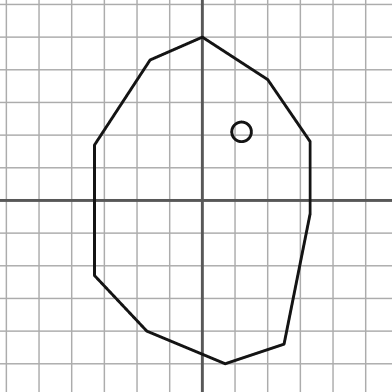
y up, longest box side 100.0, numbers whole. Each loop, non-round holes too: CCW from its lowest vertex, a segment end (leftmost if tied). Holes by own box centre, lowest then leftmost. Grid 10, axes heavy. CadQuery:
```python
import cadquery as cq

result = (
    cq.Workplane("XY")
    .moveTo(7.0, -50.0)
    .lineTo(25.0, -44.0)
    .lineTo(33.0, -4.0)
    .lineTo(33.0, 18.0)
    .lineTo(20.0, 37.0)
    .lineTo(0.0, 50.0)
    .lineTo(-16.0, 43.0)
    .lineTo(-33.0, 17.0)
    .lineTo(-33.0, -23.0)
    .lineTo(-17.0, -40.0)
    .close()
    .moveTo(12.0, 21.0)
    .circle(3.0)
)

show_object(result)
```